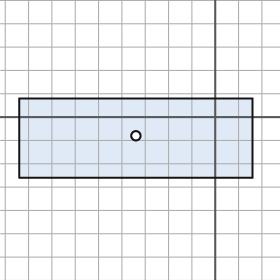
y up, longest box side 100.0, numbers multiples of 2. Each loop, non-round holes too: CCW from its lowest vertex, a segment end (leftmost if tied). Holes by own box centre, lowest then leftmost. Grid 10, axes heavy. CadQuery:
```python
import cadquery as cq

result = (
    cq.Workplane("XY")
    .moveTo(-84.0, -26.0)
    .lineTo(16.0, -26.0)
    .lineTo(16.0, 8.0)
    .lineTo(-84.0, 8.0)
    .close()
    .moveTo(-34.0, -8.0)
    .circle(2.0)
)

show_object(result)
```